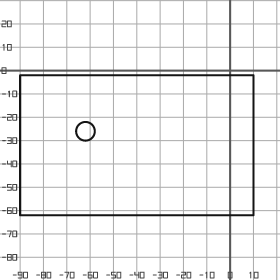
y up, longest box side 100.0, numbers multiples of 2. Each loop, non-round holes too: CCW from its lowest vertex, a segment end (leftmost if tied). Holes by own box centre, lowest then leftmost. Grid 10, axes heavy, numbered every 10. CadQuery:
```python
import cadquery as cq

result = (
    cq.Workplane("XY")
    .moveTo(-90.0, -62.0)
    .lineTo(10.0, -62.0)
    .lineTo(10.0, -2.0)
    .lineTo(-90.0, -2.0)
    .close()
    .moveTo(-62.0, -26.0)
    .circle(4.0)
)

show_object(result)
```